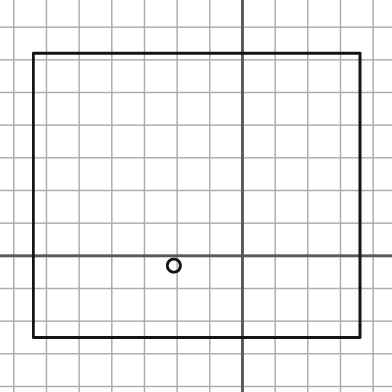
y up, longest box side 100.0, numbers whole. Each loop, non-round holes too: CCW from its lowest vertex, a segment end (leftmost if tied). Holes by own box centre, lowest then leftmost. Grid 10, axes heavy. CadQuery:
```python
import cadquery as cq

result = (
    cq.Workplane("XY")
    .moveTo(-64.0, -25.0)
    .lineTo(36.0, -25.0)
    .lineTo(36.0, 62.0)
    .lineTo(-64.0, 62.0)
    .close()
    .moveTo(-21.0, -3.0)
    .circle(2.0)
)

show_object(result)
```